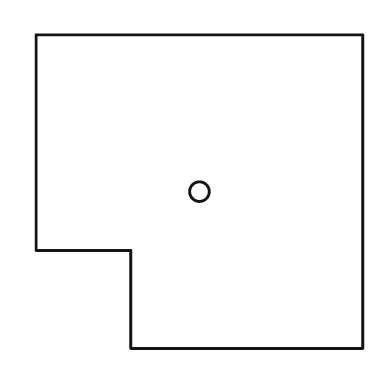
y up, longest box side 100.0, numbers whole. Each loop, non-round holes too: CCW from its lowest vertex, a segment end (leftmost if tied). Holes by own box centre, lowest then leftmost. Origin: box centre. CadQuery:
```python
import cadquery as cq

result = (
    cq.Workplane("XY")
    .moveTo(-21.0, -48.0)
    .lineTo(50.0, -48.0)
    .lineTo(50.0, 48.0)
    .lineTo(-50.0, 48.0)
    .lineTo(-50.0, -18.0)
    .lineTo(-21.0, -18.0)
    .close()
    .moveTo(0.0, 0.0)
    .circle(3.0)
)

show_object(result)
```